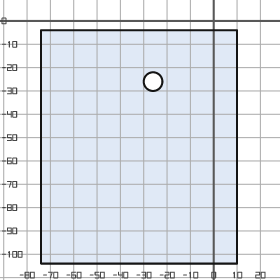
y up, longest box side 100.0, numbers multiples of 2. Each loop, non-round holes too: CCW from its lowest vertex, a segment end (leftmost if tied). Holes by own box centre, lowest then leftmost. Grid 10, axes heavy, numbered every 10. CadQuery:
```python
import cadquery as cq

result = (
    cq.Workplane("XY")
    .moveTo(-74.0, -104.0)
    .lineTo(10.0, -104.0)
    .lineTo(10.0, -4.0)
    .lineTo(-74.0, -4.0)
    .close()
    .moveTo(-26.0, -26.0)
    .circle(4.0)
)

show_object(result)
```